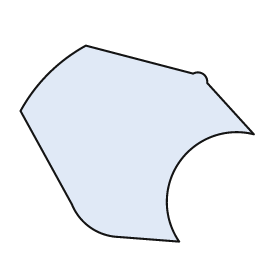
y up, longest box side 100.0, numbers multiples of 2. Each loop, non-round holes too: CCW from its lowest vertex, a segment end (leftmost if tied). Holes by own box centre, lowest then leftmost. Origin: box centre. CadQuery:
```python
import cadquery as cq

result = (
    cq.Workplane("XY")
    .moveTo(18.0, -42.0)
    .threePointArc((18.0, -8.0), (50.0, 4.0))
    .lineTo(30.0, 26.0)
    .threePointArc((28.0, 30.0), (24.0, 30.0))
    .lineTo(-22.0, 42.0)
    .threePointArc((-38.0, 30.0), (-50.0, 14.0))
    .lineTo(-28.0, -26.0)
    .threePointArc((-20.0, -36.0), (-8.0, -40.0))
    .close()
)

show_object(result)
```